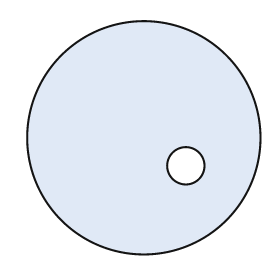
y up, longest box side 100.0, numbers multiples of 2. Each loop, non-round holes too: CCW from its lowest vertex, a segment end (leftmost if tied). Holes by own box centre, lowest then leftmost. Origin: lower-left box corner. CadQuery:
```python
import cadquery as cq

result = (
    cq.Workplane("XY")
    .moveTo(50.0, 50.0)
    .circle(50.0)
    .moveTo(68.0, 38.0)
    .circle(8.0)
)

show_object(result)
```